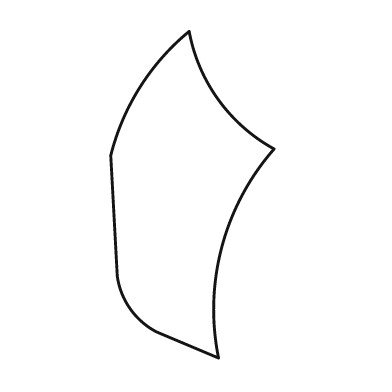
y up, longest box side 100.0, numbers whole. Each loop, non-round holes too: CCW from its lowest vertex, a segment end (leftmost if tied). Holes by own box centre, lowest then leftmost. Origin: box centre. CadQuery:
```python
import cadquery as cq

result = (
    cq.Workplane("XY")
    .moveTo(8.0, -50.0)
    .threePointArc((9.0, -16.0), (25.0, 14.0))
    .threePointArc((8.0, 29.0), (-1.0, 50.0))
    .threePointArc((-16.0, 33.0), (-25.0, 12.0))
    .lineTo(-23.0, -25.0)
    .threePointArc((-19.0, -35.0), (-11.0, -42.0))
    .close()
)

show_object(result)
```